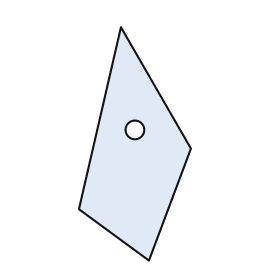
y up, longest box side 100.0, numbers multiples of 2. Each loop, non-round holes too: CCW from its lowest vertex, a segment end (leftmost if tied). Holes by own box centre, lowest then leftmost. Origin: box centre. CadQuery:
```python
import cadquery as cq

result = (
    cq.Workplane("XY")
    .moveTo(6.0, -50.0)
    .lineTo(24.0, -2.0)
    .lineTo(-6.0, 50.0)
    .lineTo(-24.0, -28.0)
    .close()
    .moveTo(0.0, 6.0)
    .circle(4.0)
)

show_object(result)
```